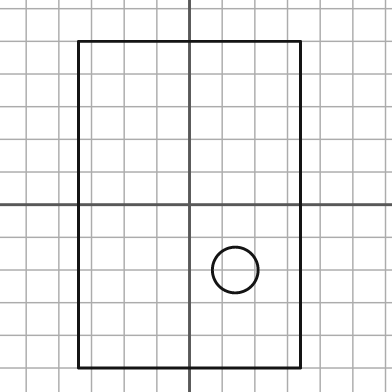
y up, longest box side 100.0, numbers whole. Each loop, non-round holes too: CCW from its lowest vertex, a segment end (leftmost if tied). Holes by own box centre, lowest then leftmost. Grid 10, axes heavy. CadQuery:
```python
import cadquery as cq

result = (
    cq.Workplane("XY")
    .moveTo(-34.0, -50.0)
    .lineTo(34.0, -50.0)
    .lineTo(34.0, 50.0)
    .lineTo(-34.0, 50.0)
    .close()
    .moveTo(14.0, -20.0)
    .circle(7.0)
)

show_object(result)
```